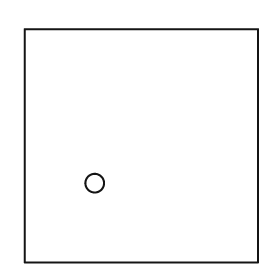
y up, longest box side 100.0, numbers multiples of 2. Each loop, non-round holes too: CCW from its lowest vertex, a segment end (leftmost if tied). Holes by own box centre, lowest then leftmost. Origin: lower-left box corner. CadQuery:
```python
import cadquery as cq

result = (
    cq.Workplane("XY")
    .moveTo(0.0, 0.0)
    .lineTo(100.0, 0.0)
    .lineTo(100.0, 100.0)
    .lineTo(0.0, 100.0)
    .close()
    .moveTo(30.0, 34.0)
    .circle(4.0)
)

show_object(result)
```